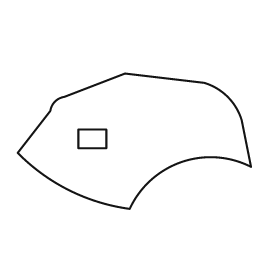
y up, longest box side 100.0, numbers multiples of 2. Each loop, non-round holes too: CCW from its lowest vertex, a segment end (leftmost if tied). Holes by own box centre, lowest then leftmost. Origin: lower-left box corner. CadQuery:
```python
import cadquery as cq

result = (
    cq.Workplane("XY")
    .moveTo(48.0, 0.0)
    .threePointArc((70.0, 20.0), (100.0, 18.0))
    .lineTo(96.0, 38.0)
    .threePointArc((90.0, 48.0), (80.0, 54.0))
    .lineTo(46.0, 58.0)
    .lineTo(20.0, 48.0)
    .threePointArc((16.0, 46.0), (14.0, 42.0))
    .lineTo(0.0, 24.0)
    .threePointArc((22.0, 8.0), (48.0, 0.0))
    .close()
    .moveTo(26.0, 26.0)
    .lineTo(38.0, 26.0)
    .lineTo(38.0, 34.0)
    .lineTo(26.0, 34.0)
    .close()
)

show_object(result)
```